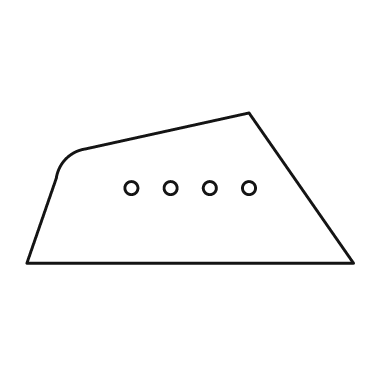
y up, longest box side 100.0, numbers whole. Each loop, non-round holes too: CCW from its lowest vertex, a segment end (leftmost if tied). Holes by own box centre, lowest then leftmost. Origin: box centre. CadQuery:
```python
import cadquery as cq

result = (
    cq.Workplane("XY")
    .moveTo(-50.0, -23.0)
    .lineTo(50.0, -23.0)
    .lineTo(18.0, 23.0)
    .lineTo(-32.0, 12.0)
    .threePointArc((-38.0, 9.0), (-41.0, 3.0))
    .close()
    .moveTo(-18.0, 0.0)
    .circle(2.0)
    .moveTo(-6.0, 0.0)
    .circle(2.0)
    .moveTo(6.0, 0.0)
    .circle(2.0)
    .moveTo(18.0, 0.0)
    .circle(2.0)
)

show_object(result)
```